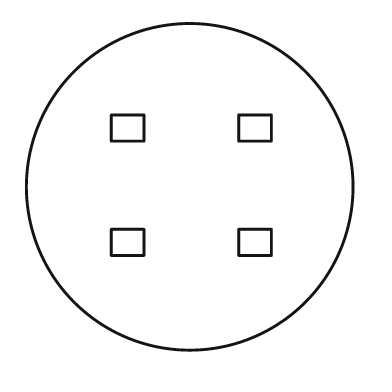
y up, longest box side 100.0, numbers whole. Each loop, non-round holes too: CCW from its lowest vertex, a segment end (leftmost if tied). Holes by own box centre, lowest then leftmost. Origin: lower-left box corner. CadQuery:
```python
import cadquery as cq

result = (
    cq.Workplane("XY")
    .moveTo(50.0, 50.0)
    .circle(50.0)
    .moveTo(26.0, 29.0)
    .lineTo(36.0, 29.0)
    .lineTo(36.0, 37.0)
    .lineTo(26.0, 37.0)
    .close()
    .moveTo(65.0, 29.0)
    .lineTo(75.0, 29.0)
    .lineTo(75.0, 37.0)
    .lineTo(65.0, 37.0)
    .close()
    .moveTo(26.0, 64.0)
    .lineTo(36.0, 64.0)
    .lineTo(36.0, 72.0)
    .lineTo(26.0, 72.0)
    .close()
    .moveTo(65.0, 64.0)
    .lineTo(75.0, 64.0)
    .lineTo(75.0, 72.0)
    .lineTo(65.0, 72.0)
    .close()
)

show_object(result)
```